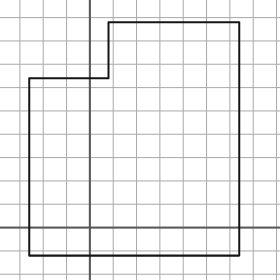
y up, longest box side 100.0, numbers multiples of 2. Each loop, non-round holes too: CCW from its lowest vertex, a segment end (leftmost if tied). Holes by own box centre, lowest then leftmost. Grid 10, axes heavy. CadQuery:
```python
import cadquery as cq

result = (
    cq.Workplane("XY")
    .moveTo(-26.0, -12.0)
    .lineTo(64.0, -12.0)
    .lineTo(64.0, 88.0)
    .lineTo(8.0, 88.0)
    .lineTo(8.0, 64.0)
    .lineTo(-26.0, 64.0)
    .close()
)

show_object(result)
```